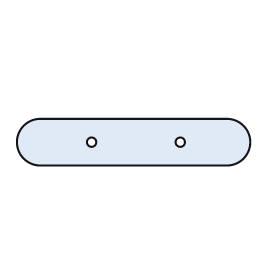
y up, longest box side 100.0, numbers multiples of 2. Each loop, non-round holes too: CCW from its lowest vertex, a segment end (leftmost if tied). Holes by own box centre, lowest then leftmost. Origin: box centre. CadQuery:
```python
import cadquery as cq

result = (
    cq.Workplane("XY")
    .moveTo(-40.0, -10.0)
    .lineTo(40.0, -10.0)
    .threePointArc((50.0, 0.0), (40.0, 10.0))
    .lineTo(-40.0, 10.0)
    .threePointArc((-50.0, 0.0), (-40.0, -10.0))
    .close()
    .moveTo(-18.0, 0.0)
    .circle(2.0)
    .moveTo(20.0, 0.0)
    .circle(2.0)
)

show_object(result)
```